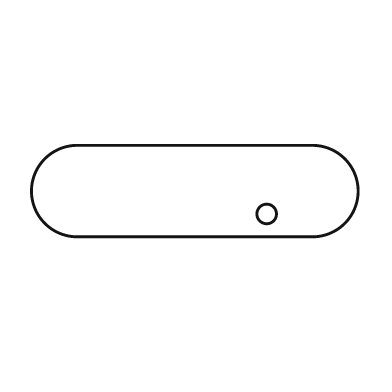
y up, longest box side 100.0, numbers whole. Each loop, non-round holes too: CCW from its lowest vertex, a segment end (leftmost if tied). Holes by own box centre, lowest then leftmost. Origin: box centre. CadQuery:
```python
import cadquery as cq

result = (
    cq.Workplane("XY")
    .moveTo(-36.0, -14.0)
    .lineTo(36.0, -14.0)
    .threePointArc((50.0, 0.0), (36.0, 14.0))
    .lineTo(-36.0, 14.0)
    .threePointArc((-50.0, 0.0), (-36.0, -14.0))
    .close()
    .moveTo(22.0, -7.0)
    .circle(3.0)
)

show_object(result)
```